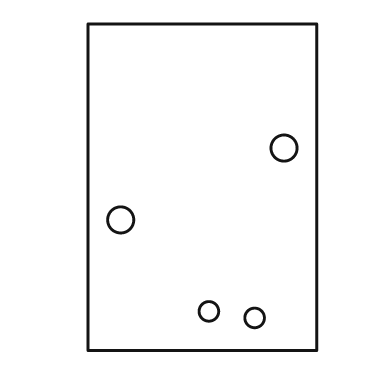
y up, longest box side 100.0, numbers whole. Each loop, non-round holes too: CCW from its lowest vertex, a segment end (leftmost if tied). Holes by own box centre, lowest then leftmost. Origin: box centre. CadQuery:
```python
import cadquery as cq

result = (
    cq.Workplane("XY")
    .moveTo(-35.0, -50.0)
    .lineTo(35.0, -50.0)
    .lineTo(35.0, 50.0)
    .lineTo(-35.0, 50.0)
    .close()
    .moveTo(16.0, -40.0)
    .circle(3.0)
    .moveTo(2.0, -38.0)
    .circle(3.0)
    .moveTo(-25.0, -10.0)
    .circle(4.0)
    .moveTo(25.0, 12.0)
    .circle(4.0)
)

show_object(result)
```